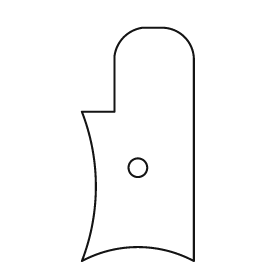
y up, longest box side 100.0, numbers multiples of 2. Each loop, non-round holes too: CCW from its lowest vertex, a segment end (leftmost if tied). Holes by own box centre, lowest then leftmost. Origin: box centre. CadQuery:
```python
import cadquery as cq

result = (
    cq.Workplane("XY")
    .moveTo(-24.0, -50.0)
    .threePointArc((0.0, -44.0), (24.0, -50.0))
    .lineTo(24.0, 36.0)
    .threePointArc((20.0, 46.0), (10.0, 50.0))
    .lineTo(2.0, 50.0)
    .threePointArc((-6.0, 46.0), (-10.0, 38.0))
    .lineTo(-10.0, 14.0)
    .lineTo(-24.0, 14.0)
    .threePointArc((-18.0, -18.0), (-24.0, -50.0))
    .close()
    .moveTo(0.0, -10.0)
    .circle(4.0)
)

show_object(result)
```